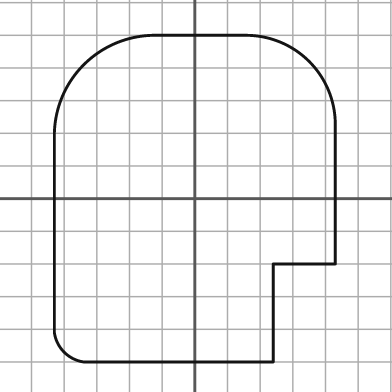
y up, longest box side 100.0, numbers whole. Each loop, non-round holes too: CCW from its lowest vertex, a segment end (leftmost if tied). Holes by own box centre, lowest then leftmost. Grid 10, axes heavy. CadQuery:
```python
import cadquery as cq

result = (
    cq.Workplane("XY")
    .moveTo(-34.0, -50.0)
    .lineTo(24.0, -50.0)
    .lineTo(24.0, -20.0)
    .lineTo(43.0, -20.0)
    .lineTo(43.0, 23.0)
    .threePointArc((35.0, 42.0), (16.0, 50.0))
    .lineTo(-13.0, 50.0)
    .threePointArc((-34.0, 41.0), (-43.0, 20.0))
    .lineTo(-43.0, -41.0)
    .threePointArc((-40.0, -47.0), (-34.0, -50.0))
    .close()
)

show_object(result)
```